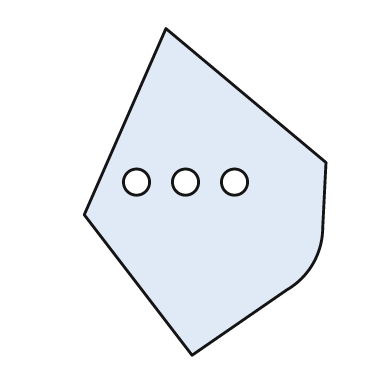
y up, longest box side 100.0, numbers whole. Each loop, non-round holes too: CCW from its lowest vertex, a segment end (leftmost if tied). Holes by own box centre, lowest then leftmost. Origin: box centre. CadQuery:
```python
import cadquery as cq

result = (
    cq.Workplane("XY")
    .moveTo(-4.0, -50.0)
    .lineTo(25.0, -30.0)
    .threePointArc((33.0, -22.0), (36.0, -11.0))
    .lineTo(37.0, 9.0)
    .lineTo(-12.0, 50.0)
    .lineTo(-37.0, -7.0)
    .close()
    .moveTo(-21.0, 3.0)
    .circle(4.0)
    .moveTo(-6.0, 3.0)
    .circle(4.0)
    .moveTo(9.0, 3.0)
    .circle(4.0)
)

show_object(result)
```